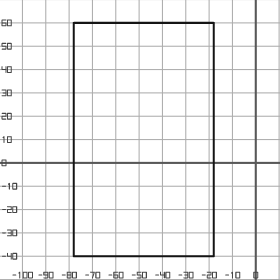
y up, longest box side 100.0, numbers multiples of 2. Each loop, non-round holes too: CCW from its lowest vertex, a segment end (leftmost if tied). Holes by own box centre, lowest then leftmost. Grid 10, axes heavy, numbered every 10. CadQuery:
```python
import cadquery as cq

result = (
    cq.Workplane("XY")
    .moveTo(-78.0, -40.0)
    .lineTo(-18.0, -40.0)
    .lineTo(-18.0, 60.0)
    .lineTo(-78.0, 60.0)
    .close()
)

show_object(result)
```